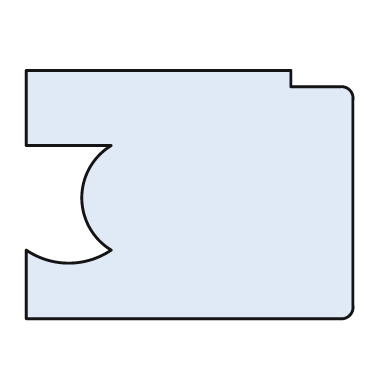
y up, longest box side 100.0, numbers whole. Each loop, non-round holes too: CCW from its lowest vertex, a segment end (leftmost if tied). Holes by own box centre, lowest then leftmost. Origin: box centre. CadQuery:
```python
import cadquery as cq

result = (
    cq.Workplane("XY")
    .moveTo(-50.0, -38.0)
    .lineTo(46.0, -38.0)
    .threePointArc((49.0, -37.0), (50.0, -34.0))
    .lineTo(50.0, 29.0)
    .threePointArc((49.0, 32.0), (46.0, 33.0))
    .lineTo(31.0, 33.0)
    .lineTo(31.0, 38.0)
    .lineTo(-50.0, 38.0)
    .lineTo(-50.0, 15.0)
    .lineTo(-24.0, 15.0)
    .threePointArc((-33.0, -1.0), (-24.0, -17.0))
    .threePointArc((-37.0, -21.0), (-50.0, -17.0))
    .close()
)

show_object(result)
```